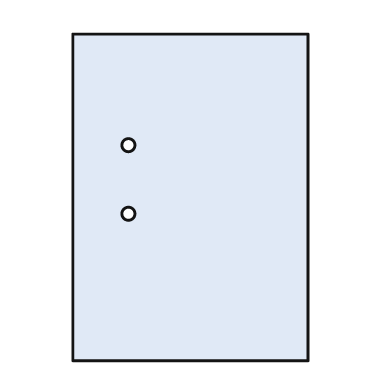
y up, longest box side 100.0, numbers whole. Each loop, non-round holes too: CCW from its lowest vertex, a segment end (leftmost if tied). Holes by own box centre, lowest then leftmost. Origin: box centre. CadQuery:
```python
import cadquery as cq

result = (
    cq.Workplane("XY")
    .moveTo(-36.0, -50.0)
    .lineTo(36.0, -50.0)
    .lineTo(36.0, 50.0)
    .lineTo(-36.0, 50.0)
    .close()
    .moveTo(-19.0, -5.0)
    .circle(2.0)
    .moveTo(-19.0, 16.0)
    .circle(2.0)
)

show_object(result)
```